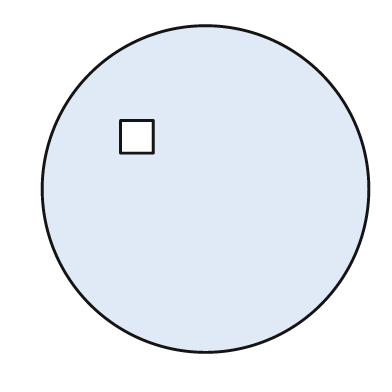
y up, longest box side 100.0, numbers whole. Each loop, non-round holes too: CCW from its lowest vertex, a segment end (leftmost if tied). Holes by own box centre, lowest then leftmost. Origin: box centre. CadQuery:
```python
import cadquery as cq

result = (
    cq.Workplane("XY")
    .moveTo(0.0, 0.0)
    .circle(50.0)
    .moveTo(-26.0, 11.0)
    .lineTo(-16.0, 11.0)
    .lineTo(-16.0, 21.0)
    .lineTo(-26.0, 21.0)
    .close()
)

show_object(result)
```